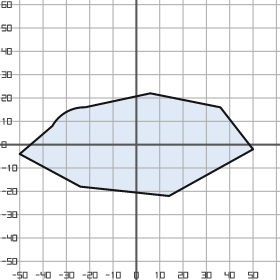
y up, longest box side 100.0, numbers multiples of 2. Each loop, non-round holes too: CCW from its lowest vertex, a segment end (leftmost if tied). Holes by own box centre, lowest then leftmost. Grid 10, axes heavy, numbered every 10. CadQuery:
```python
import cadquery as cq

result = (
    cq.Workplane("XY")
    .moveTo(14.0, -22.0)
    .lineTo(50.0, -2.0)
    .lineTo(36.0, 16.0)
    .lineTo(6.0, 22.0)
    .lineTo(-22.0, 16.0)
    .threePointArc((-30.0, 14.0), (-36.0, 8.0))
    .lineTo(-50.0, -4.0)
    .lineTo(-24.0, -18.0)
    .close()
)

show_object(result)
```